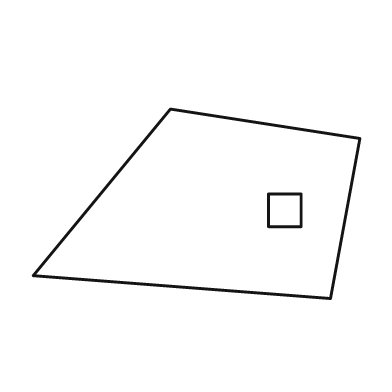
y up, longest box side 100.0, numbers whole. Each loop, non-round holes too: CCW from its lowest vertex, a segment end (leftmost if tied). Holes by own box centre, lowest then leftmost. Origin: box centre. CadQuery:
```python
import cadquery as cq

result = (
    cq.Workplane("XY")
    .moveTo(41.0, -29.0)
    .lineTo(50.0, 20.0)
    .lineTo(-8.0, 29.0)
    .lineTo(-50.0, -22.0)
    .close()
    .moveTo(22.0, -7.0)
    .lineTo(32.0, -7.0)
    .lineTo(32.0, 3.0)
    .lineTo(22.0, 3.0)
    .close()
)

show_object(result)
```